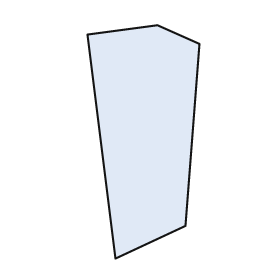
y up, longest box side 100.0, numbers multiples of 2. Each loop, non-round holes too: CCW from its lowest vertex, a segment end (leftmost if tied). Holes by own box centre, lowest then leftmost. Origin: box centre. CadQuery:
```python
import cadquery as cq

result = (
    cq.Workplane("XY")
    .moveTo(-12.0, -50.0)
    .lineTo(18.0, -36.0)
    .lineTo(24.0, 42.0)
    .lineTo(6.0, 50.0)
    .lineTo(-24.0, 46.0)
    .close()
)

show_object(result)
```